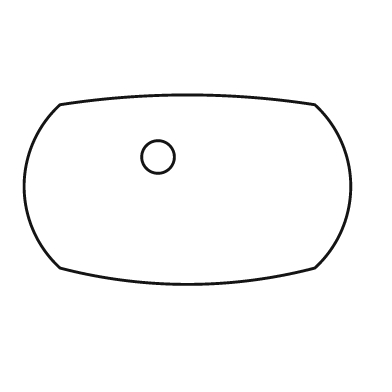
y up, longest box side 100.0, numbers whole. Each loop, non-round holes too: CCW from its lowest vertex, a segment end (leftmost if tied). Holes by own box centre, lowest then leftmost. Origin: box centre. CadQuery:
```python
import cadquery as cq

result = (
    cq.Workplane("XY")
    .moveTo(-39.0, -24.0)
    .threePointArc((0.0, -29.0), (39.0, -24.0))
    .threePointArc((50.0, 1.0), (39.0, 26.0))
    .threePointArc((0.0, 29.0), (-39.0, 26.0))
    .threePointArc((-50.0, 1.0), (-39.0, -24.0))
    .close()
    .moveTo(-9.0, 10.0)
    .circle(5.0)
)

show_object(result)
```